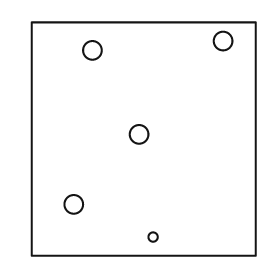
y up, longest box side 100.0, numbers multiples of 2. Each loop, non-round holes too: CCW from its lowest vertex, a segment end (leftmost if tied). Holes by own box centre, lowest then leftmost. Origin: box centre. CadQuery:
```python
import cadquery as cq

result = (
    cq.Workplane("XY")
    .moveTo(-48.0, -50.0)
    .lineTo(48.0, -50.0)
    .lineTo(48.0, 50.0)
    .lineTo(-48.0, 50.0)
    .close()
    .moveTo(4.0, -42.0)
    .circle(2.0)
    .moveTo(-30.0, -28.0)
    .circle(4.0)
    .moveTo(-2.0, 2.0)
    .circle(4.0)
    .moveTo(-22.0, 38.0)
    .circle(4.0)
    .moveTo(34.0, 42.0)
    .circle(4.0)
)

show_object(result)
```